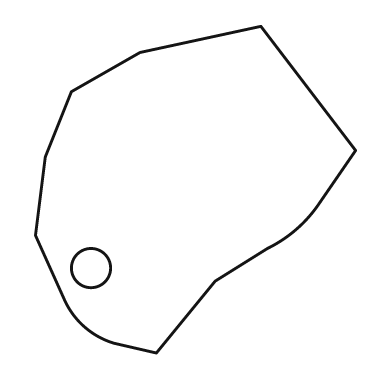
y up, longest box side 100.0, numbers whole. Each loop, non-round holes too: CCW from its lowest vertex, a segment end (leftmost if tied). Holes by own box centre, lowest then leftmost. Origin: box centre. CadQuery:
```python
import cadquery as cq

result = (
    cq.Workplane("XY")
    .moveTo(-12.0, -50.0)
    .lineTo(6.0, -28.0)
    .lineTo(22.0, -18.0)
    .threePointArc((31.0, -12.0), (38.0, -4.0))
    .lineTo(49.0, 12.0)
    .lineTo(20.0, 50.0)
    .lineTo(-17.0, 42.0)
    .lineTo(-38.0, 30.0)
    .lineTo(-46.0, 10.0)
    .lineTo(-49.0, -14.0)
    .lineTo(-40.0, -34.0)
    .threePointArc((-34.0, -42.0), (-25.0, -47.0))
    .close()
    .moveTo(-32.0, -24.0)
    .circle(6.0)
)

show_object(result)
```